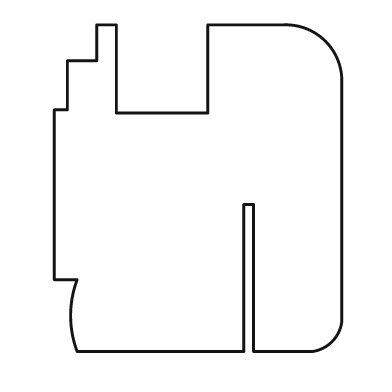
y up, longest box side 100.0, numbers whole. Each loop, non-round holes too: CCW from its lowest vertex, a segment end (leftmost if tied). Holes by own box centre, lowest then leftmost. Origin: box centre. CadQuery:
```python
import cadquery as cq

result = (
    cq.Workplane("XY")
    .moveTo(-37.0, -50.0)
    .lineTo(14.0, -50.0)
    .lineTo(14.0, -5.0)
    .lineTo(17.0, -5.0)
    .lineTo(17.0, -50.0)
    .lineTo(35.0, -50.0)
    .threePointArc((41.0, -47.0), (44.0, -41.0))
    .lineTo(44.0, 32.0)
    .threePointArc((39.0, 45.0), (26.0, 50.0))
    .lineTo(3.0, 50.0)
    .lineTo(3.0, 23.0)
    .lineTo(-25.0, 23.0)
    .lineTo(-25.0, 50.0)
    .lineTo(-31.0, 50.0)
    .lineTo(-31.0, 39.0)
    .lineTo(-40.0, 39.0)
    .lineTo(-40.0, 24.0)
    .lineTo(-44.0, 24.0)
    .lineTo(-44.0, -28.0)
    .lineTo(-37.0, -28.0)
    .threePointArc((-39.0, -39.0), (-37.0, -50.0))
    .close()
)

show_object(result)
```